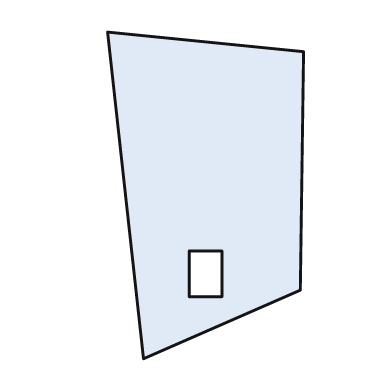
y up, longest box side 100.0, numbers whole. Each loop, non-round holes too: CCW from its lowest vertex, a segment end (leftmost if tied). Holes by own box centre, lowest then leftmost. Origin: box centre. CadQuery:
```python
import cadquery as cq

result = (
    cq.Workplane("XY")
    .moveTo(-19.0, -50.0)
    .lineTo(29.0, -29.0)
    .lineTo(30.0, 44.0)
    .lineTo(-30.0, 50.0)
    .close()
    .moveTo(-5.0, -31.0)
    .lineTo(5.0, -31.0)
    .lineTo(5.0, -17.0)
    .lineTo(-5.0, -17.0)
    .close()
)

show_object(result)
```